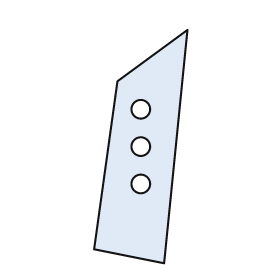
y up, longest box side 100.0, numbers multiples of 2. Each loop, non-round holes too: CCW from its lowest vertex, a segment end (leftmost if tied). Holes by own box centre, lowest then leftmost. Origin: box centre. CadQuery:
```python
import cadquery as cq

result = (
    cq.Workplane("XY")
    .moveTo(10.0, -50.0)
    .lineTo(20.0, 50.0)
    .lineTo(-10.0, 28.0)
    .lineTo(-20.0, -44.0)
    .close()
    .moveTo(0.0, -16.0)
    .circle(4.0)
    .moveTo(0.0, 0.0)
    .circle(4.0)
    .moveTo(0.0, 16.0)
    .circle(4.0)
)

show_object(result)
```